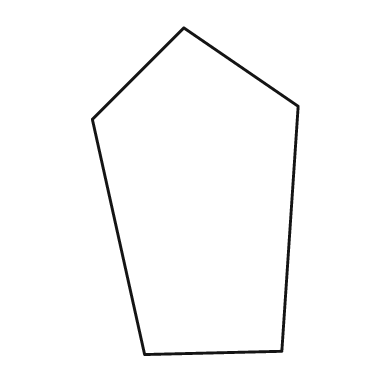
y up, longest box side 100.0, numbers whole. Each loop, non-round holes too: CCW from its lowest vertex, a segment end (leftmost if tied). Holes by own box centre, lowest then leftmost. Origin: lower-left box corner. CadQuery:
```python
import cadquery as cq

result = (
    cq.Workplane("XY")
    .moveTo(16.0, 0.0)
    .lineTo(58.0, 1.0)
    .lineTo(63.0, 76.0)
    .lineTo(28.0, 100.0)
    .lineTo(0.0, 72.0)
    .close()
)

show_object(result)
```